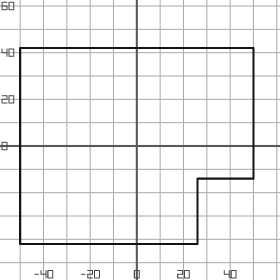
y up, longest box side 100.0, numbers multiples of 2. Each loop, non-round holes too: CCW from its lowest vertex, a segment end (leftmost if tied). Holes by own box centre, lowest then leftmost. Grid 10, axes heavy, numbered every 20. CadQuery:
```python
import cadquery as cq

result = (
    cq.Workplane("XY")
    .moveTo(-50.0, -42.0)
    .lineTo(26.0, -42.0)
    .lineTo(26.0, -14.0)
    .lineTo(50.0, -14.0)
    .lineTo(50.0, 42.0)
    .lineTo(-50.0, 42.0)
    .close()
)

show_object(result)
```